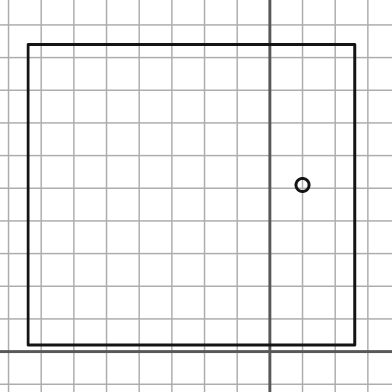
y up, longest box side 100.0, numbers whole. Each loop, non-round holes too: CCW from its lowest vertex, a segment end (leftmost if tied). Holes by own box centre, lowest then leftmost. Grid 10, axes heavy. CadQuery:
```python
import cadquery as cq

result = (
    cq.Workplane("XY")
    .moveTo(-74.0, 2.0)
    .lineTo(26.0, 2.0)
    .lineTo(26.0, 94.0)
    .lineTo(-74.0, 94.0)
    .close()
    .moveTo(10.0, 51.0)
    .circle(2.0)
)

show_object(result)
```